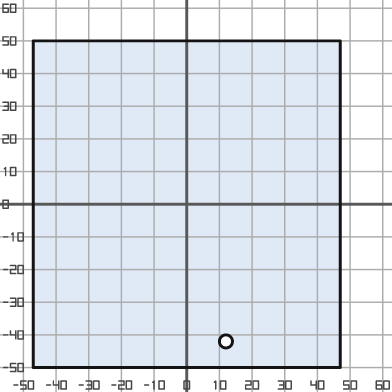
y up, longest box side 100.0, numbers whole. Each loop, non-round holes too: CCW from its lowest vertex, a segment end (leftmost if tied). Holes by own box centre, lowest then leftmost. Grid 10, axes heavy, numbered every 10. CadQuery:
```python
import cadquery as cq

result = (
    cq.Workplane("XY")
    .moveTo(-47.0, -50.0)
    .lineTo(47.0, -50.0)
    .lineTo(47.0, 50.0)
    .lineTo(-47.0, 50.0)
    .close()
    .moveTo(12.0, -42.0)
    .circle(2.0)
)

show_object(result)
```